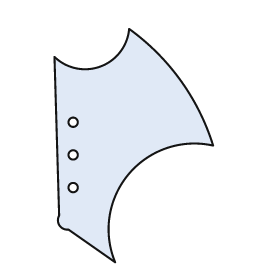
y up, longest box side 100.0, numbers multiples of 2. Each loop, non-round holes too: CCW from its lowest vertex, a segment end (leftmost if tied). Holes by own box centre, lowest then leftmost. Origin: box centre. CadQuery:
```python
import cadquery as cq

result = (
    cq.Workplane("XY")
    .moveTo(-8.0, -50.0)
    .threePointArc((-2.0, -12.0), (34.0, 0.0))
    .threePointArc((20.0, 28.0), (-2.0, 50.0))
    .threePointArc((-14.0, 34.0), (-34.0, 38.0))
    .lineTo(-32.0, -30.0)
    .threePointArc((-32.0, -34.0), (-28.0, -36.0))
    .close()
    .moveTo(-26.0, -18.0)
    .circle(2.0)
    .moveTo(-26.0, -4.0)
    .circle(2.0)
    .moveTo(-26.0, 10.0)
    .circle(2.0)
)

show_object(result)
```